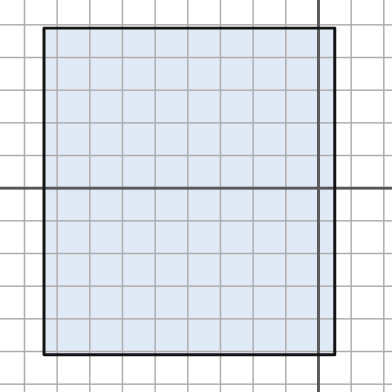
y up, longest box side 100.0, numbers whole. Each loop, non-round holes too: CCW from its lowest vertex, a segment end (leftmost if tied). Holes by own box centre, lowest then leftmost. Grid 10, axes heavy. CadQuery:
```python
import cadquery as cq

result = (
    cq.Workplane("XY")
    .moveTo(-84.0, -51.0)
    .lineTo(5.0, -51.0)
    .lineTo(5.0, 49.0)
    .lineTo(-84.0, 49.0)
    .close()
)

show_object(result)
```